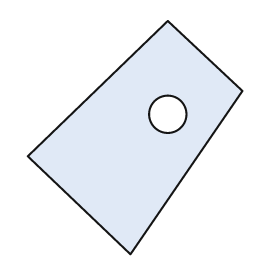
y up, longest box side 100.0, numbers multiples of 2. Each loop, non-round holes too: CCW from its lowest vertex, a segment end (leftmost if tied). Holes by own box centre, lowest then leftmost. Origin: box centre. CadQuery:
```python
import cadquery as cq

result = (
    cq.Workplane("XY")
    .moveTo(-2.0, -50.0)
    .lineTo(46.0, 20.0)
    .lineTo(14.0, 50.0)
    .lineTo(-46.0, -8.0)
    .close()
    .moveTo(14.0, 10.0)
    .circle(8.0)
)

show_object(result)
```